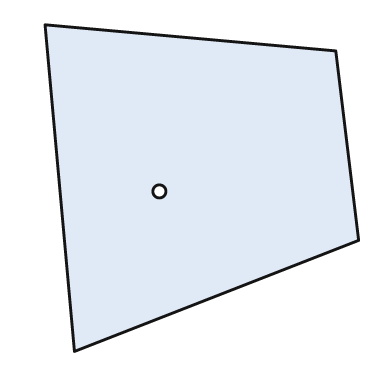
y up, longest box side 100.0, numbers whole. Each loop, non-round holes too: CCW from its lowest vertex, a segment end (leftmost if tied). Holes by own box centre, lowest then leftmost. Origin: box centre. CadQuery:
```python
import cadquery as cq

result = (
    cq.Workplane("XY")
    .moveTo(-39.0, -50.0)
    .lineTo(48.0, -16.0)
    .lineTo(41.0, 42.0)
    .lineTo(-48.0, 50.0)
    .close()
    .moveTo(-13.0, -1.0)
    .circle(2.0)
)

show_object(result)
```